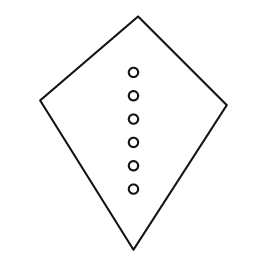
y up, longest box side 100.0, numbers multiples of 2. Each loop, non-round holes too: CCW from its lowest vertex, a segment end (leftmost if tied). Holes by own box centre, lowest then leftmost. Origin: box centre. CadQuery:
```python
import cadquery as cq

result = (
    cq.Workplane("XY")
    .moveTo(0.0, -50.0)
    .lineTo(40.0, 12.0)
    .lineTo(2.0, 50.0)
    .lineTo(-40.0, 14.0)
    .close()
    .moveTo(0.0, -24.0)
    .circle(2.0)
    .moveTo(0.0, -14.0)
    .circle(2.0)
    .moveTo(0.0, -4.0)
    .circle(2.0)
    .moveTo(0.0, 6.0)
    .circle(2.0)
    .moveTo(0.0, 16.0)
    .circle(2.0)
    .moveTo(0.0, 26.0)
    .circle(2.0)
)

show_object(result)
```